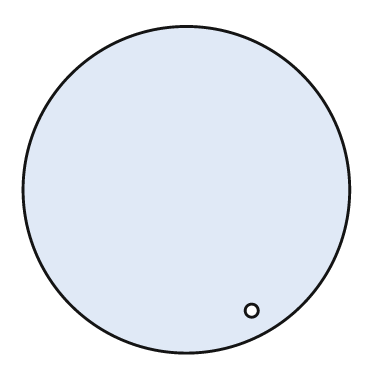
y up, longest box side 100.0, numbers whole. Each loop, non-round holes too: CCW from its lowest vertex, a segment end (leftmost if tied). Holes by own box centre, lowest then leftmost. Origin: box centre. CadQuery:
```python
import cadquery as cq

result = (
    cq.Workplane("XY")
    .moveTo(0.0, 0.0)
    .circle(50.0)
    .moveTo(20.0, -37.0)
    .circle(2.0)
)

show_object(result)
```